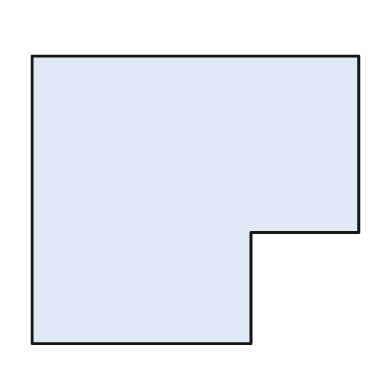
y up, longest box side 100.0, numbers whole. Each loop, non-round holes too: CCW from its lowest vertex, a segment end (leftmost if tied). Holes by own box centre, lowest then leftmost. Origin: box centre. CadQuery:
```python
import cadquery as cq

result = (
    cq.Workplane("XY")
    .moveTo(-50.0, -44.0)
    .lineTo(17.0, -44.0)
    .lineTo(17.0, -10.0)
    .lineTo(50.0, -10.0)
    .lineTo(50.0, 44.0)
    .lineTo(-50.0, 44.0)
    .close()
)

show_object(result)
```